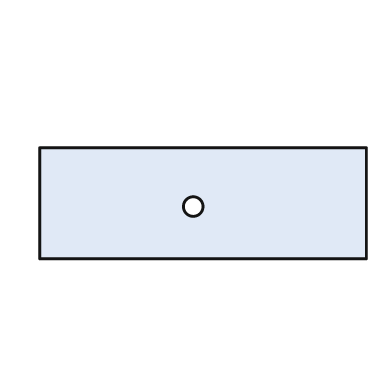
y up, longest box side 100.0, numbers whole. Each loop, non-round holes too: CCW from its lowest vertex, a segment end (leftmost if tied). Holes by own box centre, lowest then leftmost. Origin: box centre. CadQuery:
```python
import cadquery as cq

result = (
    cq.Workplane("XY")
    .moveTo(-50.0, -17.0)
    .lineTo(50.0, -17.0)
    .lineTo(50.0, 17.0)
    .lineTo(-50.0, 17.0)
    .close()
    .moveTo(-3.0, -1.0)
    .circle(3.0)
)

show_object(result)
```